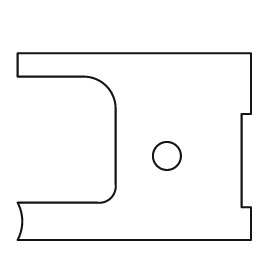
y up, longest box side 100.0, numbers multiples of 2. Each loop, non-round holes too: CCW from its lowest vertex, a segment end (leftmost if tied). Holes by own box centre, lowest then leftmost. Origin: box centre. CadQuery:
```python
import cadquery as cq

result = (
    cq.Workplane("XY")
    .moveTo(-50.0, -40.0)
    .lineTo(50.0, -40.0)
    .lineTo(50.0, -26.0)
    .lineTo(46.0, -26.0)
    .lineTo(46.0, 14.0)
    .lineTo(50.0, 14.0)
    .lineTo(50.0, 40.0)
    .lineTo(-50.0, 40.0)
    .lineTo(-50.0, 30.0)
    .lineTo(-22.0, 30.0)
    .threePointArc((-12.0, 26.0), (-8.0, 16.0))
    .lineTo(-8.0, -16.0)
    .threePointArc((-10.0, -22.0), (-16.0, -24.0))
    .lineTo(-50.0, -24.0)
    .threePointArc((-48.0, -32.0), (-50.0, -40.0))
    .close()
    .moveTo(14.0, -4.0)
    .circle(6.0)
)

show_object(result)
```